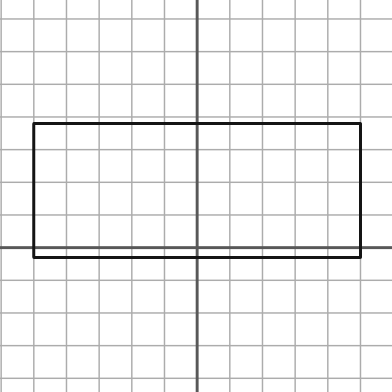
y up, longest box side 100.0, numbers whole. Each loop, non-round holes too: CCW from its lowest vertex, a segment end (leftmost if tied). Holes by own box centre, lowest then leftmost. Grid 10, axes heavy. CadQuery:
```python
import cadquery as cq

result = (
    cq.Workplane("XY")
    .moveTo(-50.0, -3.0)
    .lineTo(50.0, -3.0)
    .lineTo(50.0, 38.0)
    .lineTo(-50.0, 38.0)
    .close()
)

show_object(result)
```